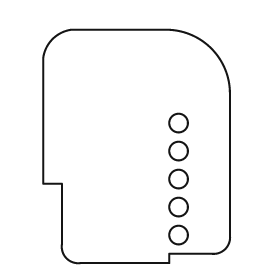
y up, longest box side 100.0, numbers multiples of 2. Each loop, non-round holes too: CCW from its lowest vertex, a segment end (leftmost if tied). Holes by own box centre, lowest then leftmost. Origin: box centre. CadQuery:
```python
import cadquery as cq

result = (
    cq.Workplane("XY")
    .moveTo(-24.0, -50.0)
    .lineTo(14.0, -50.0)
    .lineTo(14.0, -46.0)
    .lineTo(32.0, -46.0)
    .threePointArc((38.0, -44.0), (40.0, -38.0))
    .lineTo(40.0, 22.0)
    .threePointArc((32.0, 42.0), (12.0, 50.0))
    .lineTo(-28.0, 50.0)
    .threePointArc((-36.0, 46.0), (-40.0, 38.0))
    .lineTo(-40.0, -16.0)
    .lineTo(-32.0, -16.0)
    .lineTo(-32.0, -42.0)
    .threePointArc((-30.0, -48.0), (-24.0, -50.0))
    .close()
    .moveTo(18.0, -38.0)
    .circle(4.0)
    .moveTo(18.0, -26.0)
    .circle(4.0)
    .moveTo(18.0, -14.0)
    .circle(4.0)
    .moveTo(18.0, -2.0)
    .circle(4.0)
    .moveTo(18.0, 10.0)
    .circle(4.0)
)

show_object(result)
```